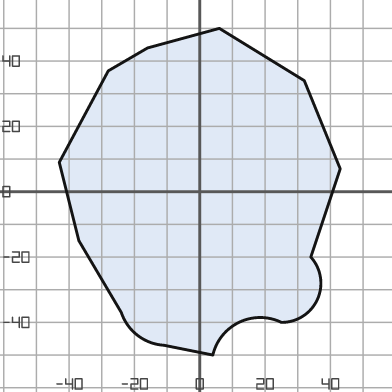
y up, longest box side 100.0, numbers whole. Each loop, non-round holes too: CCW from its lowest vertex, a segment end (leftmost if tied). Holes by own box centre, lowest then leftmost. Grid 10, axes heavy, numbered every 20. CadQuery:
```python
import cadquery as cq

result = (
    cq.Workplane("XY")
    .moveTo(4.0, -50.0)
    .threePointArc((12.0, -40.0), (25.0, -40.0))
    .threePointArc((36.0, -33.0), (34.0, -20.0))
    .lineTo(43.0, 7.0)
    .lineTo(32.0, 34.0)
    .lineTo(6.0, 50.0)
    .lineTo(-16.0, 44.0)
    .lineTo(-28.0, 37.0)
    .lineTo(-43.0, 9.0)
    .lineTo(-37.0, -15.0)
    .lineTo(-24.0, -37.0)
    .threePointArc((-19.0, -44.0), (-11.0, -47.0))
    .close()
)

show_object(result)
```